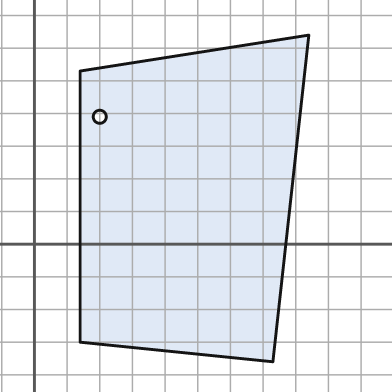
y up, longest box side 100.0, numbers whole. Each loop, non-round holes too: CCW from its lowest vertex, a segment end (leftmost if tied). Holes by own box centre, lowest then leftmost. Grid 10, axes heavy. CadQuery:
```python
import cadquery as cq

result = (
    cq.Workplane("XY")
    .moveTo(73.0, -36.0)
    .lineTo(84.0, 64.0)
    .lineTo(14.0, 53.0)
    .lineTo(14.0, -30.0)
    .close()
    .moveTo(20.0, 39.0)
    .circle(2.0)
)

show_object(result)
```